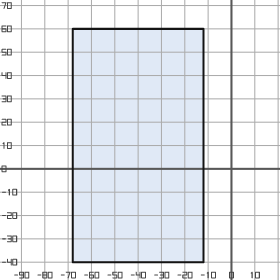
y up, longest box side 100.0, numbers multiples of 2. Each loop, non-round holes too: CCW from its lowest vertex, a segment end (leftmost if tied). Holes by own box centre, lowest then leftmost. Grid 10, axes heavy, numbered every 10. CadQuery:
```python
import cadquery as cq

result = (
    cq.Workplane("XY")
    .moveTo(-68.0, -40.0)
    .lineTo(-12.0, -40.0)
    .lineTo(-12.0, 60.0)
    .lineTo(-68.0, 60.0)
    .close()
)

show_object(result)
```